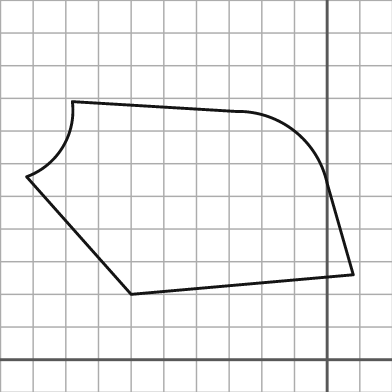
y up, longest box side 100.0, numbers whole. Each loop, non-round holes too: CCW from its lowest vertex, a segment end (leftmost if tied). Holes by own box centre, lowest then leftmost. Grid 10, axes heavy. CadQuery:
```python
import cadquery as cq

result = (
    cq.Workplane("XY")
    .moveTo(-60.0, 20.0)
    .lineTo(8.0, 26.0)
    .lineTo(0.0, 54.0)
    .threePointArc((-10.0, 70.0), (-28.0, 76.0))
    .lineTo(-78.0, 79.0)
    .threePointArc((-81.0, 65.0), (-92.0, 56.0))
    .close()
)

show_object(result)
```